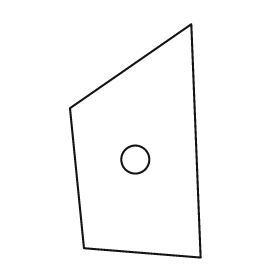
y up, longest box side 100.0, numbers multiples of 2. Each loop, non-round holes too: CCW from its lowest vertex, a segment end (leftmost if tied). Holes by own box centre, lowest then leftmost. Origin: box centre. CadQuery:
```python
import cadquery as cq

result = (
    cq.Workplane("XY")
    .moveTo(28.0, -50.0)
    .lineTo(24.0, 50.0)
    .lineTo(-28.0, 14.0)
    .lineTo(-22.0, -46.0)
    .close()
    .moveTo(0.0, -8.0)
    .circle(6.0)
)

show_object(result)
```